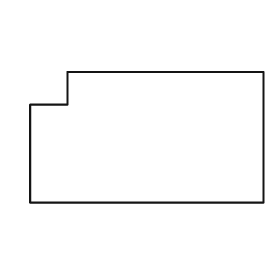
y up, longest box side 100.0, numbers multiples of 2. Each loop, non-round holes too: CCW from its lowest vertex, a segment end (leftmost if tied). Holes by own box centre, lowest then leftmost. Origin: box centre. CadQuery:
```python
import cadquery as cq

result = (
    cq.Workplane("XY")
    .moveTo(-50.0, -28.0)
    .lineTo(50.0, -28.0)
    .lineTo(50.0, 28.0)
    .lineTo(-34.0, 28.0)
    .lineTo(-34.0, 14.0)
    .lineTo(-50.0, 14.0)
    .close()
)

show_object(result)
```